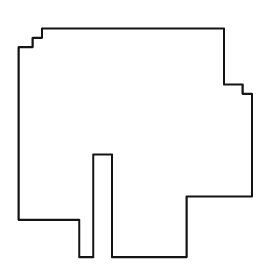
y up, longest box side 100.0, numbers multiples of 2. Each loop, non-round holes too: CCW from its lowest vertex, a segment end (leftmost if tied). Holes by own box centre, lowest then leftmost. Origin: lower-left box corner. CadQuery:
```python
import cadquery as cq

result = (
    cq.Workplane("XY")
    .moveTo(26.0, 0.0)
    .lineTo(32.0, 0.0)
    .lineTo(32.0, 44.0)
    .lineTo(40.0, 44.0)
    .lineTo(40.0, 0.0)
    .lineTo(72.0, 0.0)
    .lineTo(72.0, 26.0)
    .lineTo(100.0, 26.0)
    .lineTo(100.0, 70.0)
    .lineTo(96.0, 70.0)
    .lineTo(96.0, 74.0)
    .lineTo(88.0, 74.0)
    .lineTo(88.0, 98.0)
    .lineTo(10.0, 98.0)
    .lineTo(10.0, 94.0)
    .lineTo(6.0, 94.0)
    .lineTo(6.0, 90.0)
    .lineTo(0.0, 90.0)
    .lineTo(0.0, 16.0)
    .lineTo(26.0, 16.0)
    .close()
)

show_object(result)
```